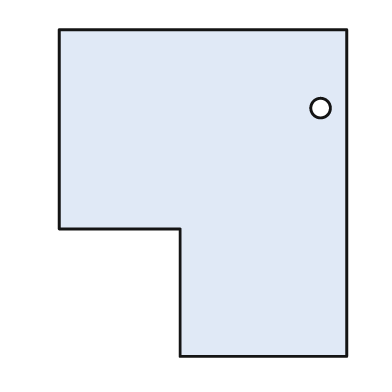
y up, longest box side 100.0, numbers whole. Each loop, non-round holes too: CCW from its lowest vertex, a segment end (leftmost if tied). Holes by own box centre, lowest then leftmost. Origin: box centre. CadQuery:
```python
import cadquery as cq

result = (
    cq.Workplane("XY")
    .moveTo(-7.0, -50.0)
    .lineTo(44.0, -50.0)
    .lineTo(44.0, 50.0)
    .lineTo(-44.0, 50.0)
    .lineTo(-44.0, -11.0)
    .lineTo(-7.0, -11.0)
    .close()
    .moveTo(36.0, 26.0)
    .circle(3.0)
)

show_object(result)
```